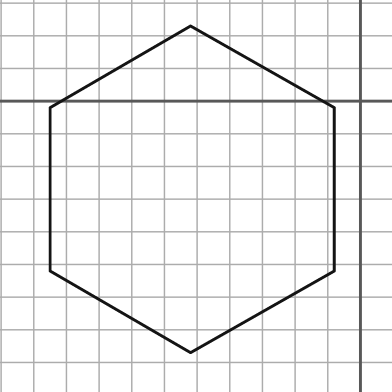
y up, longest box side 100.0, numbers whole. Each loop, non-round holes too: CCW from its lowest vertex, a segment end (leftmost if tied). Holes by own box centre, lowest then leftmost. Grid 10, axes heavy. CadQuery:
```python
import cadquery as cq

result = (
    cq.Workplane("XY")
    .moveTo(-52.0, -77.0)
    .lineTo(-8.0, -52.0)
    .lineTo(-8.0, -2.0)
    .lineTo(-52.0, 23.0)
    .lineTo(-95.0, -2.0)
    .lineTo(-95.0, -52.0)
    .close()
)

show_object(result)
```